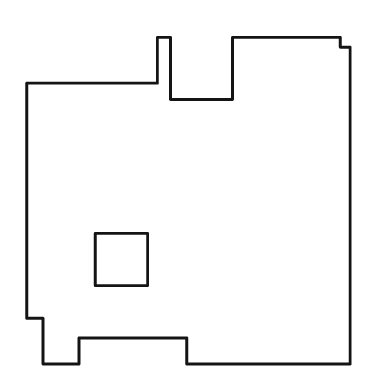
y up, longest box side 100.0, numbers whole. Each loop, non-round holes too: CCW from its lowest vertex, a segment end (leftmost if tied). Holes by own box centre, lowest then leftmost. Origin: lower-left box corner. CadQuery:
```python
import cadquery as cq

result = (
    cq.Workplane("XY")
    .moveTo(5.0, 0.0)
    .lineTo(16.0, 0.0)
    .lineTo(16.0, 8.0)
    .lineTo(49.0, 8.0)
    .lineTo(49.0, 0.0)
    .lineTo(99.0, 0.0)
    .lineTo(99.0, 97.0)
    .lineTo(96.0, 97.0)
    .lineTo(96.0, 100.0)
    .lineTo(63.0, 100.0)
    .lineTo(63.0, 81.0)
    .lineTo(44.0, 81.0)
    .lineTo(44.0, 100.0)
    .lineTo(40.0, 100.0)
    .lineTo(40.0, 86.0)
    .lineTo(0.0, 86.0)
    .lineTo(0.0, 14.0)
    .lineTo(5.0, 14.0)
    .close()
    .moveTo(21.0, 24.0)
    .lineTo(37.0, 24.0)
    .lineTo(37.0, 40.0)
    .lineTo(21.0, 40.0)
    .close()
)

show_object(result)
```